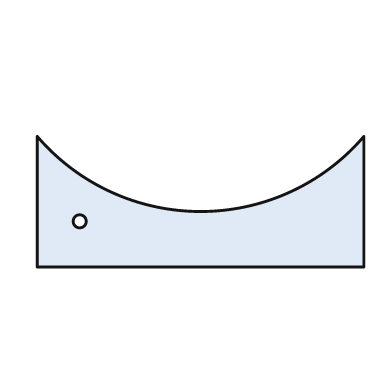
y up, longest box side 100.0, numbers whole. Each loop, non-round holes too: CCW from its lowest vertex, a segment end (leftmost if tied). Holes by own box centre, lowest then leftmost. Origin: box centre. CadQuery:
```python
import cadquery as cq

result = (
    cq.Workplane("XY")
    .moveTo(-50.0, -20.0)
    .lineTo(50.0, -20.0)
    .lineTo(50.0, 20.0)
    .threePointArc((0.0, -3.0), (-50.0, 20.0))
    .close()
    .moveTo(-37.0, -6.0)
    .circle(2.0)
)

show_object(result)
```